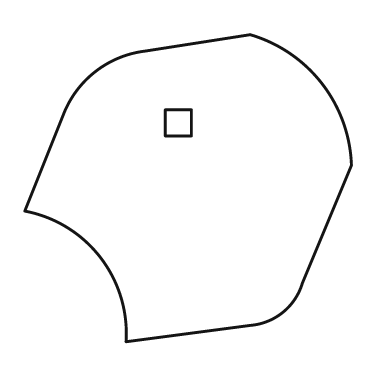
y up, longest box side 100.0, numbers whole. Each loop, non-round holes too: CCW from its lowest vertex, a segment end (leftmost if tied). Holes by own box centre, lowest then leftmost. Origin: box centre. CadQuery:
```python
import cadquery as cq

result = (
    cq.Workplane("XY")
    .moveTo(-19.0, -47.0)
    .lineTo(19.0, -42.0)
    .threePointArc((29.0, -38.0), (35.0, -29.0))
    .lineTo(50.0, 7.0)
    .threePointArc((41.0, 32.0), (19.0, 47.0))
    .lineTo(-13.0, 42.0)
    .threePointArc((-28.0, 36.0), (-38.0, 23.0))
    .lineTo(-50.0, -7.0)
    .threePointArc((-27.0, -21.0), (-19.0, -47.0))
    .close()
    .moveTo(-7.0, 16.0)
    .lineTo(1.0, 16.0)
    .lineTo(1.0, 24.0)
    .lineTo(-7.0, 24.0)
    .close()
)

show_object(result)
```